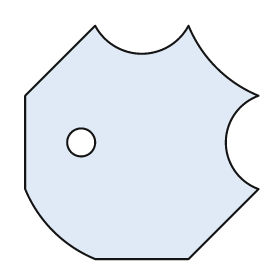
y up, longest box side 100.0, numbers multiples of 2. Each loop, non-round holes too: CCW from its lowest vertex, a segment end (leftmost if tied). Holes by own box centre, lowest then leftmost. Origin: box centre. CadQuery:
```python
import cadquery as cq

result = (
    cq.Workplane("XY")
    .moveTo(-20.0, -50.0)
    .lineTo(20.0, -50.0)
    .lineTo(50.0, -20.0)
    .threePointArc((36.0, 0.0), (50.0, 20.0))
    .threePointArc((32.0, 32.0), (20.0, 50.0))
    .threePointArc((0.0, 38.0), (-20.0, 50.0))
    .lineTo(-50.0, 20.0)
    .lineTo(-50.0, -20.0)
    .threePointArc((-38.0, -38.0), (-20.0, -50.0))
    .close()
    .moveTo(-26.0, 0.0)
    .circle(6.0)
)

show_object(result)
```